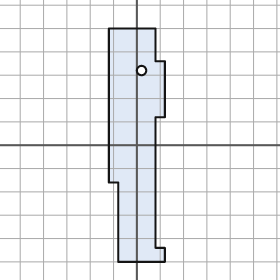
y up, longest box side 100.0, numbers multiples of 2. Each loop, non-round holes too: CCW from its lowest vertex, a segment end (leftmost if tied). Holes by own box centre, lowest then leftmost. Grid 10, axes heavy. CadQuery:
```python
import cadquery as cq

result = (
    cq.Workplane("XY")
    .moveTo(-8.0, -50.0)
    .lineTo(12.0, -50.0)
    .lineTo(12.0, -44.0)
    .lineTo(8.0, -44.0)
    .lineTo(8.0, 12.0)
    .lineTo(12.0, 12.0)
    .lineTo(12.0, 36.0)
    .lineTo(8.0, 36.0)
    .lineTo(8.0, 50.0)
    .lineTo(-12.0, 50.0)
    .lineTo(-12.0, -16.0)
    .lineTo(-8.0, -16.0)
    .close()
    .moveTo(2.0, 32.0)
    .circle(2.0)
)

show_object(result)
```